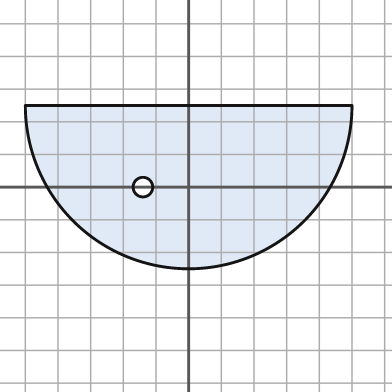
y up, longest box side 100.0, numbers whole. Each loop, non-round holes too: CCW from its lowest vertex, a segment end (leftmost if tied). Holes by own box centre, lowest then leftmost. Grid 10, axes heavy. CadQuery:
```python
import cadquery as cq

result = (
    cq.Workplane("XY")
    .moveTo(-50.0, 25.0)
    .threePointArc((0.0, -25.0), (50.0, 25.0))
    .close()
    .moveTo(-14.0, 0.0)
    .circle(3.0)
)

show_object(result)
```